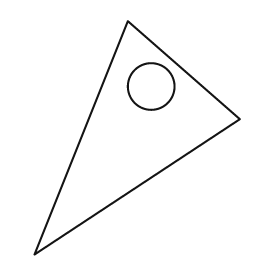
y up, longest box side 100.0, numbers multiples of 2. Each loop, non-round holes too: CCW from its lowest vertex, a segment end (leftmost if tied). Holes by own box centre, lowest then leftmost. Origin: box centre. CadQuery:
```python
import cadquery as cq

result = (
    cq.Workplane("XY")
    .moveTo(-44.0, -50.0)
    .lineTo(44.0, 8.0)
    .lineTo(-4.0, 50.0)
    .close()
    .moveTo(6.0, 22.0)
    .circle(10.0)
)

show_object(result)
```